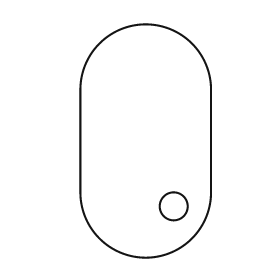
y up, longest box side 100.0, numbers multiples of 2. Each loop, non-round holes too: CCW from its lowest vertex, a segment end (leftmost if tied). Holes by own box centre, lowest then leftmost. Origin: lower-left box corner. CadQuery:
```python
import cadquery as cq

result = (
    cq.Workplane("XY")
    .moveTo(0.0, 28.0)
    .threePointArc((28.0, 0.0), (56.0, 28.0))
    .lineTo(56.0, 72.0)
    .threePointArc((28.0, 100.0), (0.0, 72.0))
    .close()
    .moveTo(40.0, 22.0)
    .circle(6.0)
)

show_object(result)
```